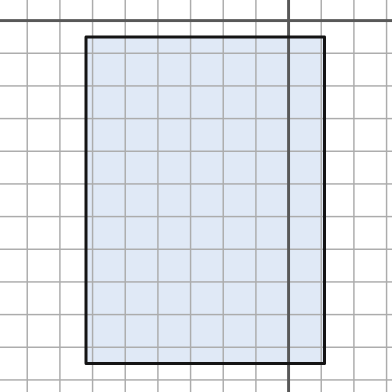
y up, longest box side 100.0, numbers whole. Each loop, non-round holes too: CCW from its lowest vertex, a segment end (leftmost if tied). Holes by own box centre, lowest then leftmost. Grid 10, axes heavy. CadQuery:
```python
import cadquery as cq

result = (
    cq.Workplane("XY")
    .moveTo(-62.0, -105.0)
    .lineTo(11.0, -105.0)
    .lineTo(11.0, -5.0)
    .lineTo(-62.0, -5.0)
    .close()
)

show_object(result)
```